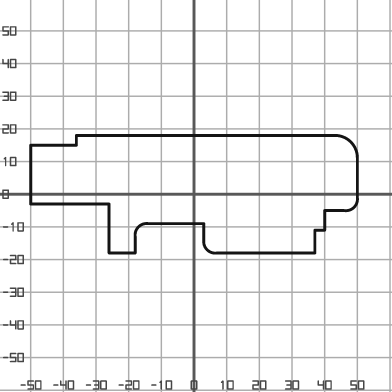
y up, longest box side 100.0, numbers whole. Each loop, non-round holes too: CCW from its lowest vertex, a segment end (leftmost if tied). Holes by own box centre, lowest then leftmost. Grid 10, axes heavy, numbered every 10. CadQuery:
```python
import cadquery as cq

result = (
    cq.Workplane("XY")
    .moveTo(-26.0, -18.0)
    .lineTo(-18.0, -18.0)
    .lineTo(-18.0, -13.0)
    .threePointArc((-17.0, -10.0), (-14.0, -9.0))
    .lineTo(3.0, -9.0)
    .lineTo(3.0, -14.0)
    .threePointArc((4.0, -17.0), (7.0, -18.0))
    .lineTo(37.0, -18.0)
    .lineTo(37.0, -11.0)
    .lineTo(40.0, -11.0)
    .lineTo(40.0, -5.0)
    .lineTo(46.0, -5.0)
    .threePointArc((49.0, -4.0), (50.0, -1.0))
    .lineTo(50.0, 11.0)
    .threePointArc((48.0, 16.0), (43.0, 18.0))
    .lineTo(-36.0, 18.0)
    .lineTo(-36.0, 15.0)
    .lineTo(-50.0, 15.0)
    .lineTo(-50.0, -3.0)
    .lineTo(-26.0, -3.0)
    .close()
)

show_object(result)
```